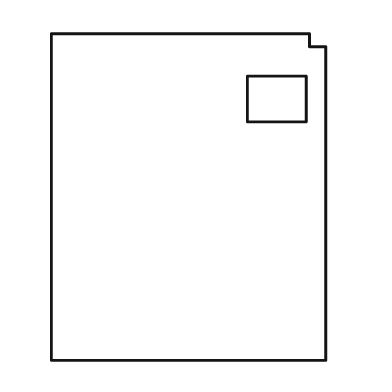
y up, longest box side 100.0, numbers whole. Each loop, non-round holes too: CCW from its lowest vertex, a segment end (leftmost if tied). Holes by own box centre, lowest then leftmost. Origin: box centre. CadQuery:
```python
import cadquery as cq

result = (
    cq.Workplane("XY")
    .moveTo(-42.0, -50.0)
    .lineTo(42.0, -50.0)
    .lineTo(42.0, 46.0)
    .lineTo(37.0, 46.0)
    .lineTo(37.0, 50.0)
    .lineTo(-42.0, 50.0)
    .close()
    .moveTo(18.0, 23.0)
    .lineTo(36.0, 23.0)
    .lineTo(36.0, 37.0)
    .lineTo(18.0, 37.0)
    .close()
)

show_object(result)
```